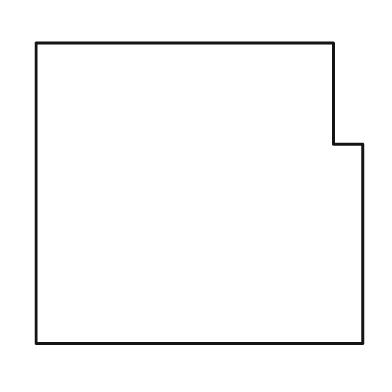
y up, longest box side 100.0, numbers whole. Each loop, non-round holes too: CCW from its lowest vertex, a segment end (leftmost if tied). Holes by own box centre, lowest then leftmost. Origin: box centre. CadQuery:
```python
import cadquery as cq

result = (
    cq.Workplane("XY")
    .moveTo(-50.0, -46.0)
    .lineTo(50.0, -46.0)
    .lineTo(50.0, 15.0)
    .lineTo(41.0, 15.0)
    .lineTo(41.0, 46.0)
    .lineTo(-50.0, 46.0)
    .close()
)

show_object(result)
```